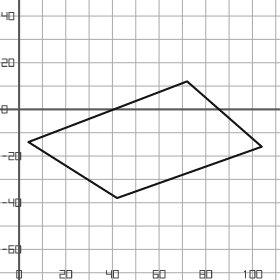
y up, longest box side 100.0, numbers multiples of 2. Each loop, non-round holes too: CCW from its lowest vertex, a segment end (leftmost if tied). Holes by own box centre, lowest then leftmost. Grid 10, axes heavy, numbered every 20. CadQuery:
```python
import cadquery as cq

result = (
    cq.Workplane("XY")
    .moveTo(42.0, -38.0)
    .lineTo(104.0, -16.0)
    .lineTo(72.0, 12.0)
    .lineTo(4.0, -14.0)
    .close()
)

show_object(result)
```